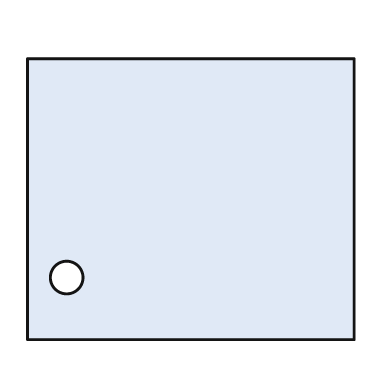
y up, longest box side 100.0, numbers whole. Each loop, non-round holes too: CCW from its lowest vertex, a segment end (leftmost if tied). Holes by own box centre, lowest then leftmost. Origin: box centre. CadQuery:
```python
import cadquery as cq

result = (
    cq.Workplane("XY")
    .moveTo(-50.0, -43.0)
    .lineTo(50.0, -43.0)
    .lineTo(50.0, 43.0)
    .lineTo(-50.0, 43.0)
    .close()
    .moveTo(-38.0, -24.0)
    .circle(5.0)
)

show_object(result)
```